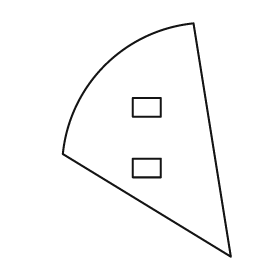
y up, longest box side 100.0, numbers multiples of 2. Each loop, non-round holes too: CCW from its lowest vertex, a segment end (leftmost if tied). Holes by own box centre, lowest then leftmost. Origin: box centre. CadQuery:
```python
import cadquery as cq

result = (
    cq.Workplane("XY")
    .moveTo(36.0, -50.0)
    .lineTo(20.0, 50.0)
    .threePointArc((-18.0, 32.0), (-36.0, -6.0))
    .close()
    .moveTo(-6.0, -16.0)
    .lineTo(6.0, -16.0)
    .lineTo(6.0, -8.0)
    .lineTo(-6.0, -8.0)
    .close()
    .moveTo(-6.0, 10.0)
    .lineTo(6.0, 10.0)
    .lineTo(6.0, 18.0)
    .lineTo(-6.0, 18.0)
    .close()
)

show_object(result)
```